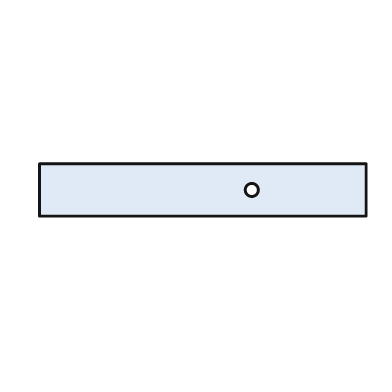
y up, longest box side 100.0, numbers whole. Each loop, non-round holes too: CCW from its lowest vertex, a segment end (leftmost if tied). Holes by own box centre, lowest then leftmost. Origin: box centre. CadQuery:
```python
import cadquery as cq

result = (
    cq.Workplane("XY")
    .moveTo(-50.0, -8.0)
    .lineTo(50.0, -8.0)
    .lineTo(50.0, 8.0)
    .lineTo(-50.0, 8.0)
    .close()
    .moveTo(15.0, 0.0)
    .circle(2.0)
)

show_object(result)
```